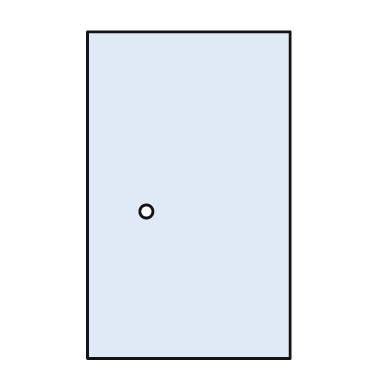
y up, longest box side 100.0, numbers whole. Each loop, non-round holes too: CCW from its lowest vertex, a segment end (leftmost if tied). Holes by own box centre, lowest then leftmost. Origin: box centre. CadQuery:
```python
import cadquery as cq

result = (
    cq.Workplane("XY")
    .moveTo(-31.0, -50.0)
    .lineTo(31.0, -50.0)
    .lineTo(31.0, 50.0)
    .lineTo(-31.0, 50.0)
    .close()
    .moveTo(-13.0, -5.0)
    .circle(2.0)
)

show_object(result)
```